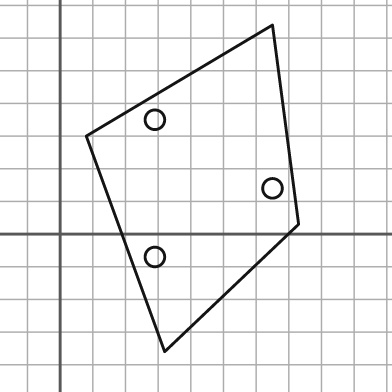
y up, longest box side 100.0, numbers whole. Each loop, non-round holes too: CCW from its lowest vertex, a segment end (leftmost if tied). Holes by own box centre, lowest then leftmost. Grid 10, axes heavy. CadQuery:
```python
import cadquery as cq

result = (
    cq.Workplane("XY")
    .moveTo(32.0, -36.0)
    .lineTo(73.0, 3.0)
    .lineTo(65.0, 64.0)
    .lineTo(8.0, 30.0)
    .close()
    .moveTo(29.0, -7.0)
    .circle(3.0)
    .moveTo(65.0, 14.0)
    .circle(3.0)
    .moveTo(29.0, 35.0)
    .circle(3.0)
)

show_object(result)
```